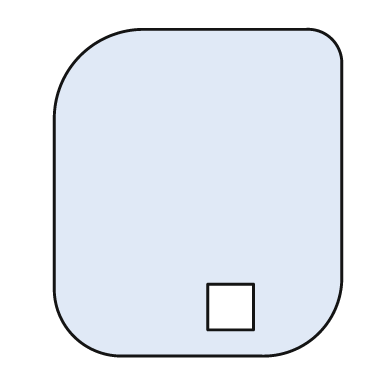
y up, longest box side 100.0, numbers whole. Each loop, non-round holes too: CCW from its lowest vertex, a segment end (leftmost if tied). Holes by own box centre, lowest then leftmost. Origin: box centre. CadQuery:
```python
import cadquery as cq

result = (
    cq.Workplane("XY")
    .moveTo(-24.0, -50.0)
    .lineTo(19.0, -50.0)
    .threePointArc((37.0, -43.0), (44.0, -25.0))
    .lineTo(44.0, 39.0)
    .threePointArc((41.0, 47.0), (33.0, 50.0))
    .lineTo(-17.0, 50.0)
    .threePointArc((-36.0, 42.0), (-44.0, 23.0))
    .lineTo(-44.0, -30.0)
    .threePointArc((-38.0, -44.0), (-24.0, -50.0))
    .close()
    .moveTo(3.0, -42.0)
    .lineTo(17.0, -42.0)
    .lineTo(17.0, -28.0)
    .lineTo(3.0, -28.0)
    .close()
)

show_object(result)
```